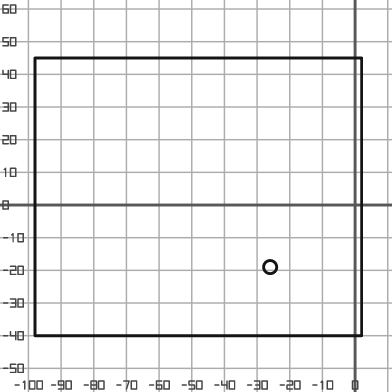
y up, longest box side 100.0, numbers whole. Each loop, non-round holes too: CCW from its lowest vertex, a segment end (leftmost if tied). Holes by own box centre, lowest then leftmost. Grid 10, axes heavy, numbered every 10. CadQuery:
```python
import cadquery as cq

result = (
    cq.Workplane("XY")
    .moveTo(-98.0, -40.0)
    .lineTo(2.0, -40.0)
    .lineTo(2.0, 45.0)
    .lineTo(-98.0, 45.0)
    .close()
    .moveTo(-26.0, -19.0)
    .circle(2.0)
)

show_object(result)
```